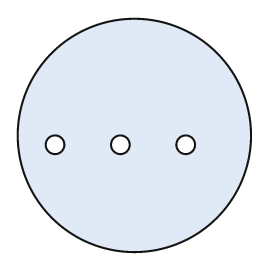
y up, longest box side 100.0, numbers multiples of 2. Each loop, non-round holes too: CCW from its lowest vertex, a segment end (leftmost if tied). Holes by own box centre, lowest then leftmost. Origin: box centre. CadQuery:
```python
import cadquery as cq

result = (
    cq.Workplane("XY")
    .moveTo(0.0, 0.0)
    .circle(50.0)
    .moveTo(-34.0, -4.0)
    .circle(4.0)
    .moveTo(-6.0, -4.0)
    .circle(4.0)
    .moveTo(22.0, -4.0)
    .circle(4.0)
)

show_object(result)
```